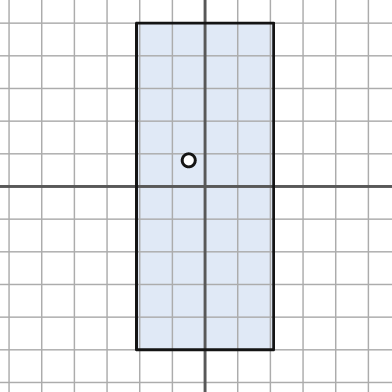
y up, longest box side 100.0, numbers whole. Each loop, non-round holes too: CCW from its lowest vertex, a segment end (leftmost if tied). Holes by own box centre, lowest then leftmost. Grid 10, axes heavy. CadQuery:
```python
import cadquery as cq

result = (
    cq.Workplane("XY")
    .moveTo(-21.0, -50.0)
    .lineTo(21.0, -50.0)
    .lineTo(21.0, 50.0)
    .lineTo(-21.0, 50.0)
    .close()
    .moveTo(-5.0, 8.0)
    .circle(2.0)
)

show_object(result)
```